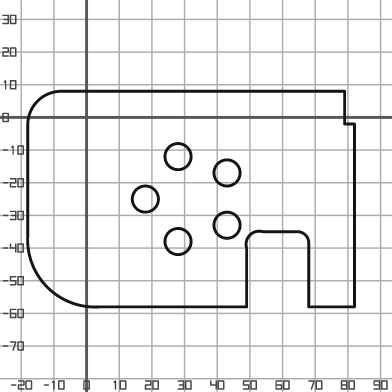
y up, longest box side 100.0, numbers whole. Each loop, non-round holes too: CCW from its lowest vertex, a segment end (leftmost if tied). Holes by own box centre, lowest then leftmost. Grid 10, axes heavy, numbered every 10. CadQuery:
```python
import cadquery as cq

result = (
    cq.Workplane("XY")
    .moveTo(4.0, -58.0)
    .lineTo(49.0, -58.0)
    .lineTo(49.0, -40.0)
    .threePointArc((50.0, -36.0), (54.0, -35.0))
    .lineTo(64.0, -35.0)
    .threePointArc((67.0, -36.0), (68.0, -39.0))
    .lineTo(68.0, -58.0)
    .lineTo(82.0, -58.0)
    .lineTo(82.0, -2.0)
    .lineTo(79.0, -2.0)
    .lineTo(79.0, 8.0)
    .lineTo(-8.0, 8.0)
    .threePointArc((-15.0, 5.0), (-18.0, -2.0))
    .lineTo(-18.0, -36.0)
    .threePointArc((-12.0, -52.0), (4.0, -58.0))
    .close()
    .moveTo(28.0, -38.0)
    .circle(4.0)
    .moveTo(43.0, -33.0)
    .circle(4.0)
    .moveTo(18.0, -25.0)
    .circle(4.0)
    .moveTo(43.0, -17.0)
    .circle(4.0)
    .moveTo(28.0, -12.0)
    .circle(4.0)
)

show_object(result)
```